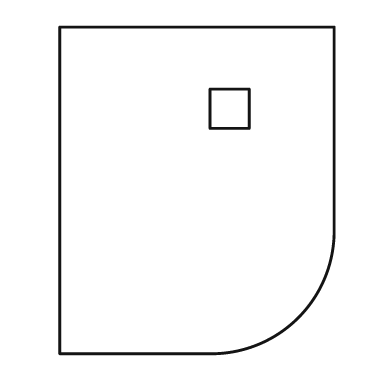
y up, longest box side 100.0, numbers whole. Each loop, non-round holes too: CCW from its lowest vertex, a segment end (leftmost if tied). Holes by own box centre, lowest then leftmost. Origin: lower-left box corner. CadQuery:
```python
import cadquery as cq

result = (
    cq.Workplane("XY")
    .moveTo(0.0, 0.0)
    .lineTo(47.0, 0.0)
    .threePointArc((73.0, 11.0), (84.0, 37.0))
    .lineTo(84.0, 100.0)
    .lineTo(0.0, 100.0)
    .close()
    .moveTo(46.0, 69.0)
    .lineTo(58.0, 69.0)
    .lineTo(58.0, 81.0)
    .lineTo(46.0, 81.0)
    .close()
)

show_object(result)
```